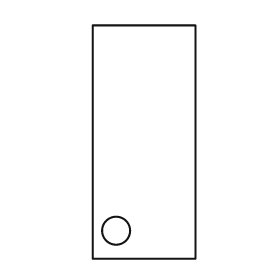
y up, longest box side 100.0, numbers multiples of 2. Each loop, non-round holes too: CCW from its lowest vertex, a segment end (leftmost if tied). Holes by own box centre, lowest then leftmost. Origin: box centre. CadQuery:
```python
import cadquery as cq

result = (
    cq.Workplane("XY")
    .moveTo(-22.0, -50.0)
    .lineTo(22.0, -50.0)
    .lineTo(22.0, 50.0)
    .lineTo(-22.0, 50.0)
    .close()
    .moveTo(-12.0, -38.0)
    .circle(6.0)
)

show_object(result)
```